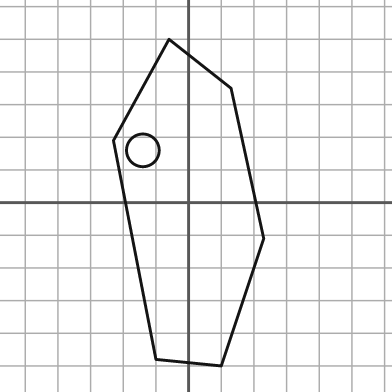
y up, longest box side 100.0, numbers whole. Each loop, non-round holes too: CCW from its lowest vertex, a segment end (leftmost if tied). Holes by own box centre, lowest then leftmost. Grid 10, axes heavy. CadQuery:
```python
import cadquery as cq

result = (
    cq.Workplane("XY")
    .moveTo(10.0, -50.0)
    .lineTo(23.0, -11.0)
    .lineTo(13.0, 35.0)
    .lineTo(-6.0, 50.0)
    .lineTo(-23.0, 19.0)
    .lineTo(-10.0, -48.0)
    .close()
    .moveTo(-14.0, 16.0)
    .circle(5.0)
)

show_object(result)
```